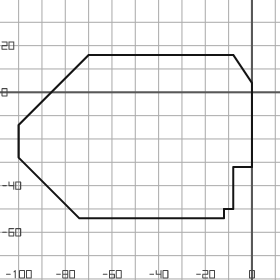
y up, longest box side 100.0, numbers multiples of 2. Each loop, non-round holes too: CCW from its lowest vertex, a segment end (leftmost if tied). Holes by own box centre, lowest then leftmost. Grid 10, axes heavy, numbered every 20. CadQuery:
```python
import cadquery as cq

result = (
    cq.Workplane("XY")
    .moveTo(-74.0, -54.0)
    .lineTo(-12.0, -54.0)
    .lineTo(-12.0, -50.0)
    .lineTo(-8.0, -50.0)
    .lineTo(-8.0, -32.0)
    .lineTo(0.0, -32.0)
    .lineTo(0.0, 4.0)
    .lineTo(-8.0, 16.0)
    .lineTo(-70.0, 16.0)
    .lineTo(-100.0, -14.0)
    .lineTo(-100.0, -28.0)
    .close()
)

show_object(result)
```